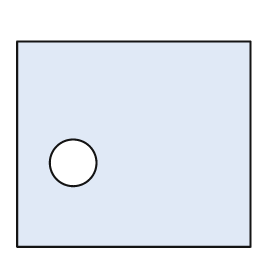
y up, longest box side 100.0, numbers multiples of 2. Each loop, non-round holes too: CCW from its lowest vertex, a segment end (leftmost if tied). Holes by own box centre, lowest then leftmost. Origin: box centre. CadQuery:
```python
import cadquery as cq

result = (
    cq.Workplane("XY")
    .moveTo(-50.0, -44.0)
    .lineTo(50.0, -44.0)
    .lineTo(50.0, 44.0)
    .lineTo(-50.0, 44.0)
    .close()
    .moveTo(-26.0, -8.0)
    .circle(10.0)
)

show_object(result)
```